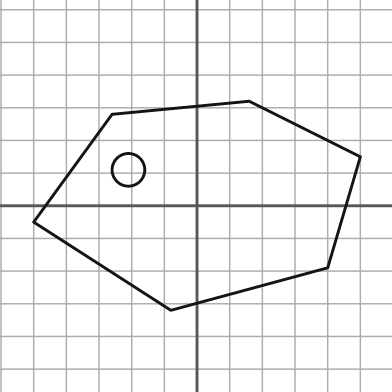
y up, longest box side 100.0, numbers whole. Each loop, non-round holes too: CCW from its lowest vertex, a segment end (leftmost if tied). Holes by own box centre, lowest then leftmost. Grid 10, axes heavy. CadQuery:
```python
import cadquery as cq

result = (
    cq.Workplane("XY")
    .moveTo(-8.0, -32.0)
    .lineTo(40.0, -19.0)
    .lineTo(50.0, 15.0)
    .lineTo(16.0, 32.0)
    .lineTo(-26.0, 28.0)
    .lineTo(-50.0, -5.0)
    .close()
    .moveTo(-21.0, 11.0)
    .circle(5.0)
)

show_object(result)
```